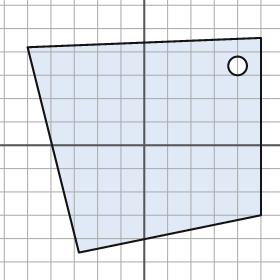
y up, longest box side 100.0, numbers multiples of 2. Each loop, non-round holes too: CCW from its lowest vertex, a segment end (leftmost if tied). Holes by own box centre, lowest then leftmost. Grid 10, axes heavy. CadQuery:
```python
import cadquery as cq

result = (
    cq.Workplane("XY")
    .moveTo(-28.0, -46.0)
    .lineTo(50.0, -30.0)
    .lineTo(50.0, 46.0)
    .lineTo(-50.0, 42.0)
    .close()
    .moveTo(40.0, 34.0)
    .circle(4.0)
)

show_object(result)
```